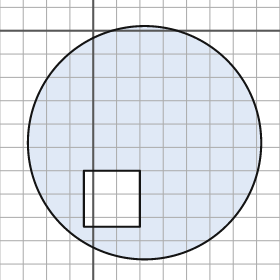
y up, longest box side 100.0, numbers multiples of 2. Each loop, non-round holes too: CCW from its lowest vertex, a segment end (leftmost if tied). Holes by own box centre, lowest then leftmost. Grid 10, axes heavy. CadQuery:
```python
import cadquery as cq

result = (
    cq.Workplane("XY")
    .moveTo(22.0, -48.0)
    .circle(50.0)
    .moveTo(-4.0, -84.0)
    .lineTo(20.0, -84.0)
    .lineTo(20.0, -60.0)
    .lineTo(-4.0, -60.0)
    .close()
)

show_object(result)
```